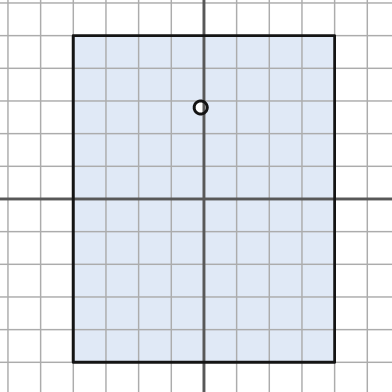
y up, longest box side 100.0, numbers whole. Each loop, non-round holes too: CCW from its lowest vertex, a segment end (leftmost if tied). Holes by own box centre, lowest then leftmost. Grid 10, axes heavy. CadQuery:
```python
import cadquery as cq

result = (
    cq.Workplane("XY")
    .moveTo(-40.0, -50.0)
    .lineTo(40.0, -50.0)
    .lineTo(40.0, 50.0)
    .lineTo(-40.0, 50.0)
    .close()
    .moveTo(-1.0, 28.0)
    .circle(2.0)
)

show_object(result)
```